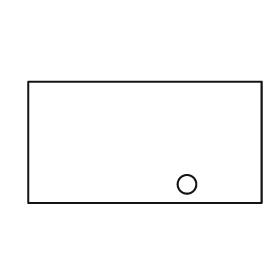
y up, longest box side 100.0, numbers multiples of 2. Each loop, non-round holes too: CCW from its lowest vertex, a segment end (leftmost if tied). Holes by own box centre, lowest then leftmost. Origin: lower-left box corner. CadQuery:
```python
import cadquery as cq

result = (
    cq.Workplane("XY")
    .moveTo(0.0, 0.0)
    .lineTo(100.0, 0.0)
    .lineTo(100.0, 52.0)
    .lineTo(0.0, 52.0)
    .close()
    .moveTo(68.0, 8.0)
    .circle(4.0)
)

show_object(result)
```